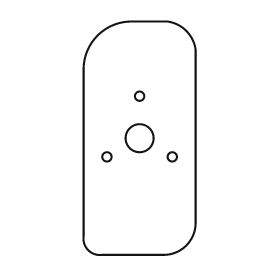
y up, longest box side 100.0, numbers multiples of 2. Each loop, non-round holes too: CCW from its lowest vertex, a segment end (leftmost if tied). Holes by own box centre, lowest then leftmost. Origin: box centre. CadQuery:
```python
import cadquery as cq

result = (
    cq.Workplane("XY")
    .moveTo(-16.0, -50.0)
    .lineTo(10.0, -50.0)
    .threePointArc((20.0, -46.0), (24.0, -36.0))
    .lineTo(24.0, 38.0)
    .threePointArc((20.0, 46.0), (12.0, 50.0))
    .lineTo(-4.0, 50.0)
    .threePointArc((-18.0, 44.0), (-24.0, 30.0))
    .lineTo(-24.0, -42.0)
    .threePointArc((-22.0, -48.0), (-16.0, -50.0))
    .close()
    .moveTo(-14.0, -8.0)
    .circle(2.0)
    .moveTo(14.0, -8.0)
    .circle(2.0)
    .moveTo(0.0, 0.0)
    .circle(6.0)
    .moveTo(0.0, 18.0)
    .circle(2.0)
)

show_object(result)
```